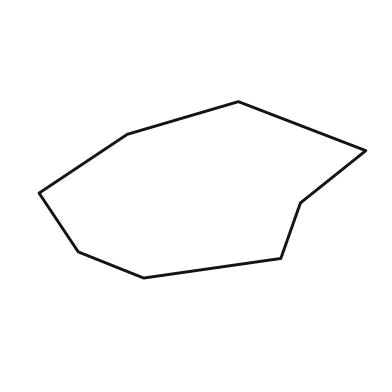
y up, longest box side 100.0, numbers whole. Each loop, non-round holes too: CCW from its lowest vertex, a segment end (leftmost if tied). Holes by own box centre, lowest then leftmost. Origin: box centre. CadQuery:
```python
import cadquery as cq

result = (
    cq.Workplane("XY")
    .moveTo(-18.0, -27.0)
    .lineTo(24.0, -21.0)
    .lineTo(30.0, -4.0)
    .lineTo(50.0, 12.0)
    .lineTo(11.0, 27.0)
    .lineTo(-23.0, 17.0)
    .lineTo(-50.0, -1.0)
    .lineTo(-38.0, -19.0)
    .close()
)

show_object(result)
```